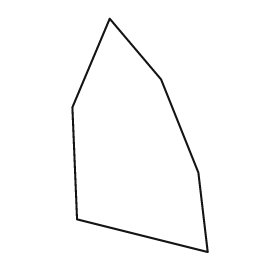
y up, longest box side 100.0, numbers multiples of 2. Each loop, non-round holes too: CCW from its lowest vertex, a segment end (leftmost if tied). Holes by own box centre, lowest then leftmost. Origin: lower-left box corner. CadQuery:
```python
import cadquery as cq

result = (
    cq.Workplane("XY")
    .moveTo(58.0, 0.0)
    .lineTo(54.0, 34.0)
    .lineTo(38.0, 74.0)
    .lineTo(16.0, 100.0)
    .lineTo(0.0, 62.0)
    .lineTo(2.0, 14.0)
    .close()
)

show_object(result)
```